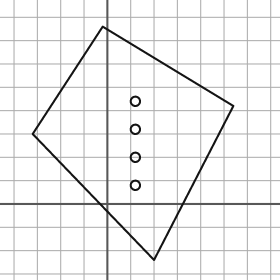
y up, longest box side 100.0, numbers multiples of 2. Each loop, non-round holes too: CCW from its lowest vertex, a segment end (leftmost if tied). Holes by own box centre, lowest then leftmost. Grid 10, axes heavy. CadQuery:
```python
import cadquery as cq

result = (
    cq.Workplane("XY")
    .moveTo(20.0, -24.0)
    .lineTo(54.0, 42.0)
    .lineTo(-2.0, 76.0)
    .lineTo(-32.0, 30.0)
    .close()
    .moveTo(12.0, 8.0)
    .circle(2.0)
    .moveTo(12.0, 20.0)
    .circle(2.0)
    .moveTo(12.0, 32.0)
    .circle(2.0)
    .moveTo(12.0, 44.0)
    .circle(2.0)
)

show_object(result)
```